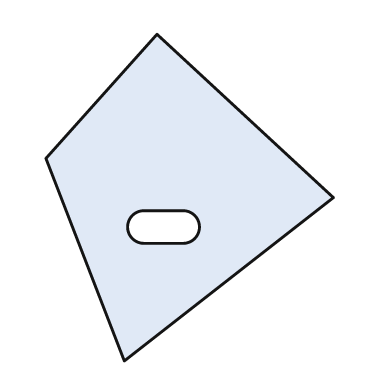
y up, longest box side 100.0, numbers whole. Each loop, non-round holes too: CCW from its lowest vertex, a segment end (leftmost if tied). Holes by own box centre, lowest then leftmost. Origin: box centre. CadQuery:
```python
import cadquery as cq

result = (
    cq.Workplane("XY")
    .moveTo(-20.0, -50.0)
    .lineTo(44.0, 0.0)
    .lineTo(-10.0, 50.0)
    .lineTo(-44.0, 12.0)
    .close()
    .moveTo(-14.0, -14.0)
    .lineTo(-2.0, -14.0)
    .threePointArc((3.0, -9.0), (-2.0, -4.0))
    .lineTo(-14.0, -4.0)
    .threePointArc((-19.0, -9.0), (-14.0, -14.0))
    .close()
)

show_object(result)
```